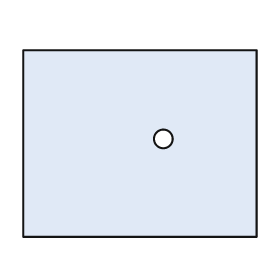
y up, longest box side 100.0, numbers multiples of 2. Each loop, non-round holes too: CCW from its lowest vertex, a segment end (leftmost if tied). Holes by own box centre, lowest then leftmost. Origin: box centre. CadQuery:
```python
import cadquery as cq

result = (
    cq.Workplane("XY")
    .moveTo(-50.0, -40.0)
    .lineTo(50.0, -40.0)
    .lineTo(50.0, 40.0)
    .lineTo(-50.0, 40.0)
    .close()
    .moveTo(10.0, 2.0)
    .circle(4.0)
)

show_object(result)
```